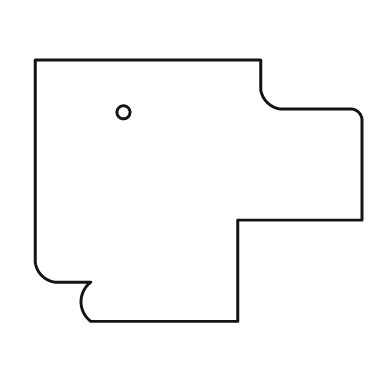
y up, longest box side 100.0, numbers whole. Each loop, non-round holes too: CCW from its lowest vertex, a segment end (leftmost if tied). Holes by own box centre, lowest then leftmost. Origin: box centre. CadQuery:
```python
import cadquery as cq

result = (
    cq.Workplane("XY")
    .moveTo(-33.0, -40.0)
    .lineTo(12.0, -40.0)
    .lineTo(12.0, -9.0)
    .lineTo(50.0, -9.0)
    .lineTo(50.0, 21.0)
    .threePointArc((49.0, 24.0), (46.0, 25.0))
    .lineTo(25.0, 25.0)
    .threePointArc((21.0, 27.0), (19.0, 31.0))
    .lineTo(19.0, 40.0)
    .lineTo(-50.0, 40.0)
    .lineTo(-50.0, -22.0)
    .threePointArc((-48.0, -26.0), (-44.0, -28.0))
    .lineTo(-33.0, -28.0)
    .threePointArc((-36.0, -34.0), (-33.0, -40.0))
    .close()
    .moveTo(-23.0, 24.0)
    .circle(2.0)
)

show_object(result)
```